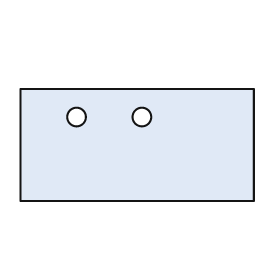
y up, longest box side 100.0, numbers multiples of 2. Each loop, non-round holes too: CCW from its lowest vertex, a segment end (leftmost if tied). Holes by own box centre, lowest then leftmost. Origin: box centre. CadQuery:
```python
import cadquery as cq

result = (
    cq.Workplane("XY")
    .moveTo(-50.0, -24.0)
    .lineTo(50.0, -24.0)
    .lineTo(50.0, 24.0)
    .lineTo(-50.0, 24.0)
    .close()
    .moveTo(-26.0, 12.0)
    .circle(4.0)
    .moveTo(2.0, 12.0)
    .circle(4.0)
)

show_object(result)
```